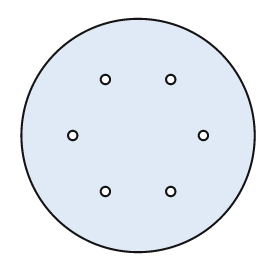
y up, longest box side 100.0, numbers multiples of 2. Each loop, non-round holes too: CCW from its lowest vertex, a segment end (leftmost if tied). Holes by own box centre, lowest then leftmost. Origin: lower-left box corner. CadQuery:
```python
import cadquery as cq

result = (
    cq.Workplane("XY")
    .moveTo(50.0, 50.0)
    .circle(50.0)
    .moveTo(36.0, 26.0)
    .circle(2.0)
    .moveTo(64.0, 26.0)
    .circle(2.0)
    .moveTo(22.0, 50.0)
    .circle(2.0)
    .moveTo(78.0, 50.0)
    .circle(2.0)
    .moveTo(36.0, 74.0)
    .circle(2.0)
    .moveTo(64.0, 74.0)
    .circle(2.0)
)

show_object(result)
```